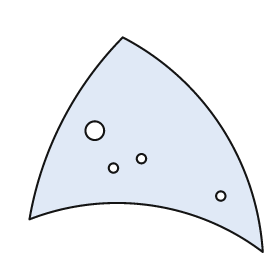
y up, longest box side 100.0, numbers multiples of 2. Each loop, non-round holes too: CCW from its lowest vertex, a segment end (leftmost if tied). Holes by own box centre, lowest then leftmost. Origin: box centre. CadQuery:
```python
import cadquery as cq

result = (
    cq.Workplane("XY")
    .moveTo(50.0, -46.0)
    .threePointArc((32.0, 8.0), (-10.0, 46.0))
    .threePointArc((-36.0, 10.0), (-50.0, -32.0))
    .threePointArc((2.0, -26.0), (50.0, -46.0))
    .close()
    .moveTo(32.0, -22.0)
    .circle(2.0)
    .moveTo(-14.0, -10.0)
    .circle(2.0)
    .moveTo(-2.0, -6.0)
    .circle(2.0)
    .moveTo(-22.0, 6.0)
    .circle(4.0)
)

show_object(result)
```